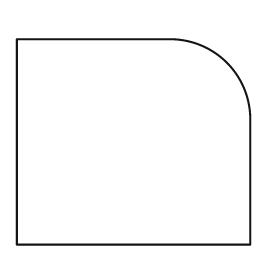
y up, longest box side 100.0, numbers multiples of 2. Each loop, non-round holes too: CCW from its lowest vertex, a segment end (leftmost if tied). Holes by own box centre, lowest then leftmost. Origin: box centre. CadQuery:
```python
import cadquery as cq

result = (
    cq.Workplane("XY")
    .moveTo(-50.0, -44.0)
    .lineTo(50.0, -44.0)
    .lineTo(50.0, 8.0)
    .threePointArc((40.0, 34.0), (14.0, 44.0))
    .lineTo(-50.0, 44.0)
    .close()
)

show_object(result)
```